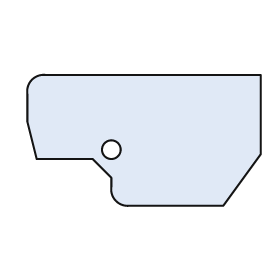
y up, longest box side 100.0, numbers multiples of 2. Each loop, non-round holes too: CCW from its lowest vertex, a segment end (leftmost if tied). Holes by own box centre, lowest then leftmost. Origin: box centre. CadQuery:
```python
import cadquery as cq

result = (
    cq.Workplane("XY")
    .moveTo(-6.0, -28.0)
    .lineTo(34.0, -28.0)
    .lineTo(50.0, -6.0)
    .lineTo(50.0, 28.0)
    .lineTo(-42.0, 28.0)
    .threePointArc((-48.0, 26.0), (-50.0, 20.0))
    .lineTo(-50.0, 8.0)
    .lineTo(-46.0, -8.0)
    .lineTo(-22.0, -8.0)
    .lineTo(-14.0, -16.0)
    .lineTo(-14.0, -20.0)
    .threePointArc((-12.0, -26.0), (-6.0, -28.0))
    .close()
    .moveTo(-14.0, -4.0)
    .circle(4.0)
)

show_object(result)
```